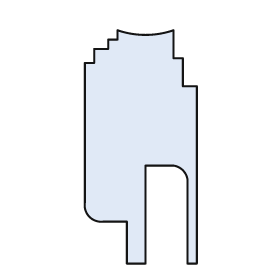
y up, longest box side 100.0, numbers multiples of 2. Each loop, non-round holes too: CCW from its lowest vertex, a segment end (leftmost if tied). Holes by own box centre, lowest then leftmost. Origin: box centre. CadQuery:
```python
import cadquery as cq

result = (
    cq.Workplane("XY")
    .moveTo(-6.0, -50.0)
    .lineTo(2.0, -50.0)
    .lineTo(2.0, -8.0)
    .lineTo(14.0, -8.0)
    .threePointArc((18.0, -10.0), (20.0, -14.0))
    .lineTo(20.0, -50.0)
    .lineTo(24.0, -50.0)
    .lineTo(24.0, 26.0)
    .lineTo(18.0, 26.0)
    .lineTo(18.0, 38.0)
    .lineTo(14.0, 38.0)
    .lineTo(14.0, 50.0)
    .threePointArc((2.0, 48.0), (-10.0, 50.0))
    .lineTo(-10.0, 46.0)
    .lineTo(-14.0, 46.0)
    .lineTo(-14.0, 42.0)
    .lineTo(-20.0, 42.0)
    .lineTo(-20.0, 36.0)
    .lineTo(-24.0, 36.0)
    .lineTo(-24.0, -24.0)
    .threePointArc((-22.0, -30.0), (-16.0, -32.0))
    .lineTo(-6.0, -32.0)
    .close()
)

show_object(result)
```